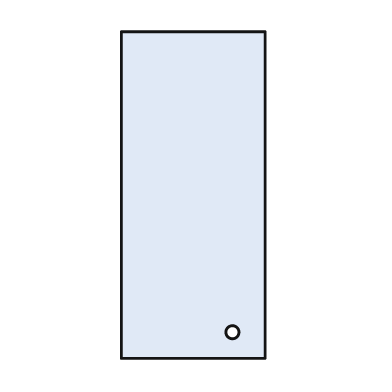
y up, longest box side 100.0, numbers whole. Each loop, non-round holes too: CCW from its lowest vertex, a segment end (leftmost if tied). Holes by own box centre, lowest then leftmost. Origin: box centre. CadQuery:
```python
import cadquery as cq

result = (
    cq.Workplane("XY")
    .moveTo(-22.0, -50.0)
    .lineTo(22.0, -50.0)
    .lineTo(22.0, 50.0)
    .lineTo(-22.0, 50.0)
    .close()
    .moveTo(12.0, -42.0)
    .circle(2.0)
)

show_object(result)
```